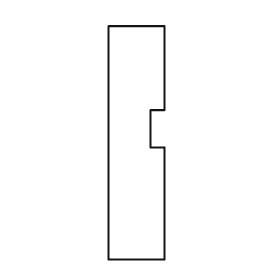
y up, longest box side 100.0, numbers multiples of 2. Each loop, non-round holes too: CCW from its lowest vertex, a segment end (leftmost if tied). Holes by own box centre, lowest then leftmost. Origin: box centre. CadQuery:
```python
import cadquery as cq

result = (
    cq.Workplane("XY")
    .moveTo(-12.0, -50.0)
    .lineTo(12.0, -50.0)
    .lineTo(12.0, -2.0)
    .lineTo(6.0, -2.0)
    .lineTo(6.0, 14.0)
    .lineTo(12.0, 14.0)
    .lineTo(12.0, 50.0)
    .lineTo(-12.0, 50.0)
    .close()
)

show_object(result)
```